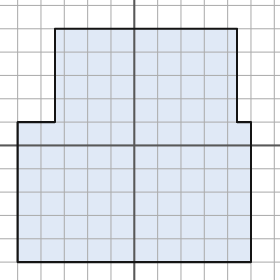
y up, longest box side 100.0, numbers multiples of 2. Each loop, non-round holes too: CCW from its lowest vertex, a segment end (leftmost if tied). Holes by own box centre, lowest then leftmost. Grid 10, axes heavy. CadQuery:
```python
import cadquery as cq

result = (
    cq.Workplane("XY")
    .moveTo(-50.0, -50.0)
    .lineTo(50.0, -50.0)
    .lineTo(50.0, 10.0)
    .lineTo(44.0, 10.0)
    .lineTo(44.0, 50.0)
    .lineTo(-34.0, 50.0)
    .lineTo(-34.0, 10.0)
    .lineTo(-50.0, 10.0)
    .close()
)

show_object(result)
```